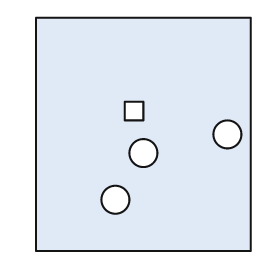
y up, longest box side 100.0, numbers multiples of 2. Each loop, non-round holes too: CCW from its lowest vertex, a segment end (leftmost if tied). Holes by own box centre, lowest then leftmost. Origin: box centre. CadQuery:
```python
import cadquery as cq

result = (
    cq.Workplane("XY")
    .moveTo(-46.0, -50.0)
    .lineTo(46.0, -50.0)
    .lineTo(46.0, 50.0)
    .lineTo(-46.0, 50.0)
    .close()
    .moveTo(-12.0, -28.0)
    .circle(6.0)
    .moveTo(0.0, -8.0)
    .circle(6.0)
    .moveTo(36.0, 0.0)
    .circle(6.0)
    .moveTo(-8.0, 6.0)
    .lineTo(0.0, 6.0)
    .lineTo(0.0, 14.0)
    .lineTo(-8.0, 14.0)
    .close()
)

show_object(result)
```